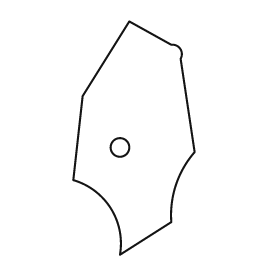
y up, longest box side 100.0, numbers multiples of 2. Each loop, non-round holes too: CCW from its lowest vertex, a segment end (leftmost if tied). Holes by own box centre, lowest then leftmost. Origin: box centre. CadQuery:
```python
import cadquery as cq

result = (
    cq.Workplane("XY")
    .moveTo(-6.0, -50.0)
    .lineTo(16.0, -36.0)
    .threePointArc((18.0, -20.0), (26.0, -6.0))
    .lineTo(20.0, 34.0)
    .threePointArc((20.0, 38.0), (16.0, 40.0))
    .lineTo(-2.0, 50.0)
    .lineTo(-22.0, 18.0)
    .lineTo(-26.0, -18.0)
    .threePointArc((-10.0, -30.0), (-6.0, -50.0))
    .close()
    .moveTo(-6.0, -4.0)
    .circle(4.0)
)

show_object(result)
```